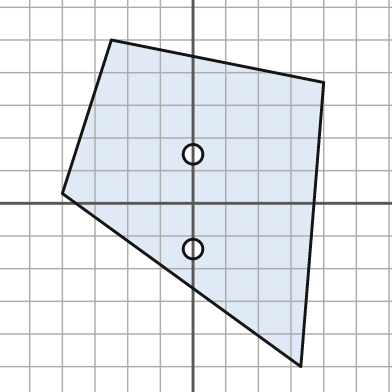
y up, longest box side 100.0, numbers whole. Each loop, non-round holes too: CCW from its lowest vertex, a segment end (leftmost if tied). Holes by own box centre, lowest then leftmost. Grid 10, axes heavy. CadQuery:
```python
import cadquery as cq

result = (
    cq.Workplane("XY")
    .moveTo(33.0, -50.0)
    .lineTo(40.0, 37.0)
    .lineTo(-25.0, 50.0)
    .lineTo(-40.0, 3.0)
    .close()
    .moveTo(0.0, -14.0)
    .circle(3.0)
    .moveTo(0.0, 15.0)
    .circle(3.0)
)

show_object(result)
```